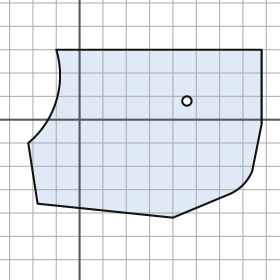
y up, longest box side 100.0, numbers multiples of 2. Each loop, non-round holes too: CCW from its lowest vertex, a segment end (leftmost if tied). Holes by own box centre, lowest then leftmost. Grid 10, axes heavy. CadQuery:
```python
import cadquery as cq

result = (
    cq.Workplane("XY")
    .moveTo(40.0, -42.0)
    .lineTo(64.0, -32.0)
    .threePointArc((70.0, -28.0), (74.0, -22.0))
    .lineTo(78.0, -2.0)
    .lineTo(78.0, 30.0)
    .lineTo(-10.0, 30.0)
    .threePointArc((-10.0, 8.0), (-22.0, -10.0))
    .lineTo(-18.0, -36.0)
    .close()
    .moveTo(46.0, 8.0)
    .circle(2.0)
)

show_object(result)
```